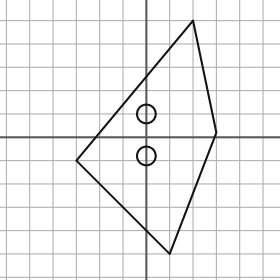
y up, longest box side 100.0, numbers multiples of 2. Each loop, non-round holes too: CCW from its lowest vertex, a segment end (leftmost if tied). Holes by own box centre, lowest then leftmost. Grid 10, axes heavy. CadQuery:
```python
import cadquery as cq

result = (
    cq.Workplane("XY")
    .moveTo(10.0, -50.0)
    .lineTo(30.0, 2.0)
    .lineTo(20.0, 50.0)
    .lineTo(-30.0, -10.0)
    .close()
    .moveTo(0.0, -8.0)
    .circle(4.0)
    .moveTo(0.0, 10.0)
    .circle(4.0)
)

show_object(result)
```